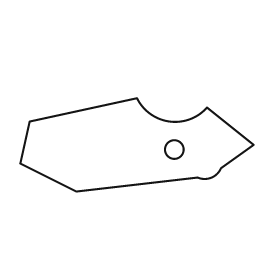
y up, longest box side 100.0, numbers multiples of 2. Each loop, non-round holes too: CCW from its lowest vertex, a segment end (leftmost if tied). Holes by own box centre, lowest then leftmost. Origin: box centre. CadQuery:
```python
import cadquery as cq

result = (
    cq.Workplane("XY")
    .moveTo(-26.0, -20.0)
    .lineTo(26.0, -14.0)
    .threePointArc((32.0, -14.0), (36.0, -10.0))
    .lineTo(50.0, 0.0)
    .lineTo(30.0, 16.0)
    .threePointArc((14.0, 10.0), (0.0, 20.0))
    .lineTo(-46.0, 10.0)
    .lineTo(-50.0, -8.0)
    .close()
    .moveTo(16.0, -2.0)
    .circle(4.0)
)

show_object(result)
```